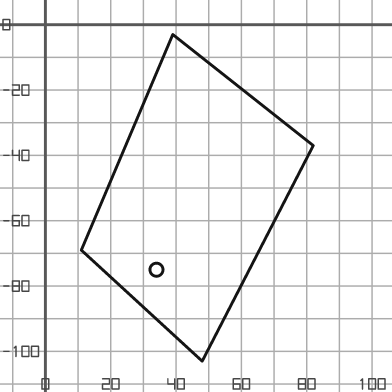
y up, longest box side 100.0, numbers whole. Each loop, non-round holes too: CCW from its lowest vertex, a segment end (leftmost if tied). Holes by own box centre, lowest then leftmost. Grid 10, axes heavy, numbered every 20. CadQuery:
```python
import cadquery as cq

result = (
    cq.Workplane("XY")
    .moveTo(48.0, -103.0)
    .lineTo(82.0, -37.0)
    .lineTo(39.0, -3.0)
    .lineTo(11.0, -69.0)
    .close()
    .moveTo(34.0, -75.0)
    .circle(2.0)
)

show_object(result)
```